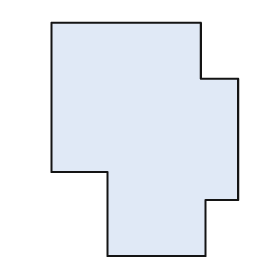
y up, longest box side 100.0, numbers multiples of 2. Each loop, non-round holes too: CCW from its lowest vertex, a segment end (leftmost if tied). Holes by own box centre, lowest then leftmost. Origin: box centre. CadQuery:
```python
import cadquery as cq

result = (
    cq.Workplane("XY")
    .moveTo(-16.0, -50.0)
    .lineTo(26.0, -50.0)
    .lineTo(26.0, -26.0)
    .lineTo(40.0, -26.0)
    .lineTo(40.0, 26.0)
    .lineTo(24.0, 26.0)
    .lineTo(24.0, 50.0)
    .lineTo(-40.0, 50.0)
    .lineTo(-40.0, -14.0)
    .lineTo(-16.0, -14.0)
    .close()
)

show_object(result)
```